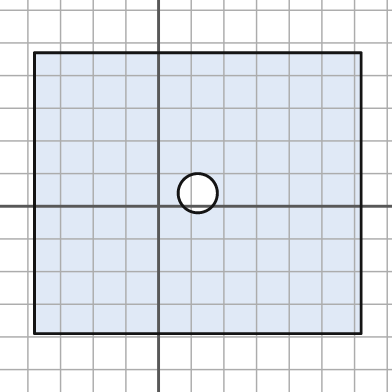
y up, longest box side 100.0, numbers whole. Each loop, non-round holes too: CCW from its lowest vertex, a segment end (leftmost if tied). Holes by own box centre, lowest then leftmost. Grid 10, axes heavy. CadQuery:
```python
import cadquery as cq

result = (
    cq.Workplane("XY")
    .moveTo(-38.0, -39.0)
    .lineTo(62.0, -39.0)
    .lineTo(62.0, 47.0)
    .lineTo(-38.0, 47.0)
    .close()
    .moveTo(12.0, 4.0)
    .circle(6.0)
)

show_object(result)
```